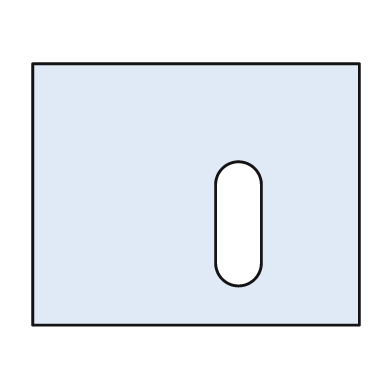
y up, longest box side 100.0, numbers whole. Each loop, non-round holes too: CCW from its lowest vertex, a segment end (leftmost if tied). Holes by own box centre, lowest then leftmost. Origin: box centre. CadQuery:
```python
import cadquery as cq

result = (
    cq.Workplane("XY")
    .moveTo(-50.0, -40.0)
    .lineTo(50.0, -40.0)
    .lineTo(50.0, 40.0)
    .lineTo(-50.0, 40.0)
    .close()
    .moveTo(6.0, -21.0)
    .threePointArc((13.0, -28.0), (20.0, -21.0))
    .lineTo(20.0, 3.0)
    .threePointArc((13.0, 10.0), (6.0, 3.0))
    .close()
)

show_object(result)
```